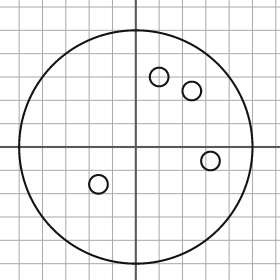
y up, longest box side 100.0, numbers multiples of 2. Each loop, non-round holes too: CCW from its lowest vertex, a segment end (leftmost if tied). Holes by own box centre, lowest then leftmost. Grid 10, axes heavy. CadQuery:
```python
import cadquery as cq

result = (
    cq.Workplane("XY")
    .moveTo(0.0, 0.0)
    .circle(50.0)
    .moveTo(-16.0, -16.0)
    .circle(4.0)
    .moveTo(32.0, -6.0)
    .circle(4.0)
    .moveTo(24.0, 24.0)
    .circle(4.0)
    .moveTo(10.0, 30.0)
    .circle(4.0)
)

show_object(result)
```